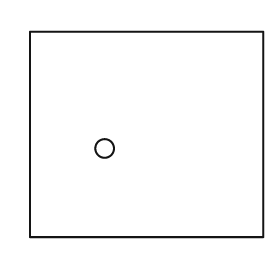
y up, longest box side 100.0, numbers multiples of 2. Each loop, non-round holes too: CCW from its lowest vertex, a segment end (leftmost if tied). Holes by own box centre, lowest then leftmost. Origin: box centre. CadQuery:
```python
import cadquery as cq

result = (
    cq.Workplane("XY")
    .moveTo(-50.0, -44.0)
    .lineTo(50.0, -44.0)
    .lineTo(50.0, 44.0)
    .lineTo(-50.0, 44.0)
    .close()
    .moveTo(-18.0, -6.0)
    .circle(4.0)
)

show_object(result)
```